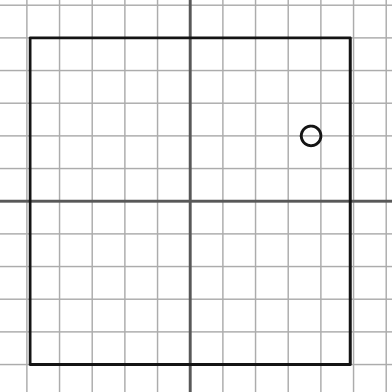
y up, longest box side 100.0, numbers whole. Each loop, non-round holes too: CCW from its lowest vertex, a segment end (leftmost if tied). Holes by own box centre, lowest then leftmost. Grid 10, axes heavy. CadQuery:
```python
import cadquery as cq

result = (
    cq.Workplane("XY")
    .moveTo(-49.0, -50.0)
    .lineTo(49.0, -50.0)
    .lineTo(49.0, 50.0)
    .lineTo(-49.0, 50.0)
    .close()
    .moveTo(37.0, 20.0)
    .circle(3.0)
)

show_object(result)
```